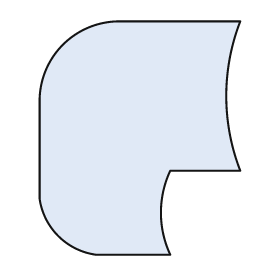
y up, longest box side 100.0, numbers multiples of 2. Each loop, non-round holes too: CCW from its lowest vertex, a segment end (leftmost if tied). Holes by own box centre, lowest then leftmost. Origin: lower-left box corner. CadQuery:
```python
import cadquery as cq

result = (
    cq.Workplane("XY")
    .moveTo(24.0, 0.0)
    .lineTo(56.0, 0.0)
    .threePointArc((52.0, 18.0), (56.0, 36.0))
    .lineTo(86.0, 36.0)
    .threePointArc((80.0, 68.0), (86.0, 100.0))
    .lineTo(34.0, 100.0)
    .threePointArc((10.0, 90.0), (0.0, 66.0))
    .lineTo(0.0, 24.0)
    .threePointArc((8.0, 8.0), (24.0, 0.0))
    .close()
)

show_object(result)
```